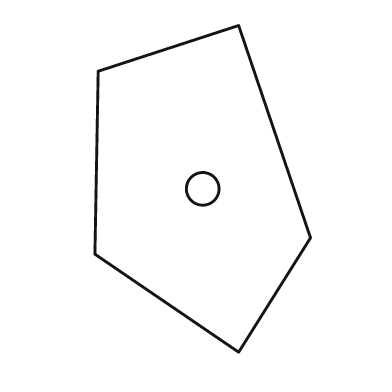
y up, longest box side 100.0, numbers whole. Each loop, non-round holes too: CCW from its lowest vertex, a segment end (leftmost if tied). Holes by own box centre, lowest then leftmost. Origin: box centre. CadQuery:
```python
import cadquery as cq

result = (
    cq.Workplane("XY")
    .moveTo(11.0, -50.0)
    .lineTo(33.0, -15.0)
    .lineTo(11.0, 50.0)
    .lineTo(-32.0, 36.0)
    .lineTo(-33.0, -20.0)
    .close()
    .moveTo(0.0, 0.0)
    .circle(5.0)
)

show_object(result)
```